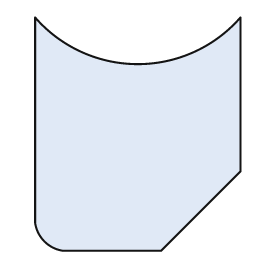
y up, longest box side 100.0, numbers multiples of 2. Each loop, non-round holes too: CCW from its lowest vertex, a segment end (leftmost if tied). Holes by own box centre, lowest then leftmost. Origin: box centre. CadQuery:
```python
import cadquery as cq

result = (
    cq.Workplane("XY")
    .moveTo(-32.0, -50.0)
    .lineTo(10.0, -50.0)
    .lineTo(44.0, -16.0)
    .lineTo(44.0, 50.0)
    .threePointArc((0.0, 30.0), (-44.0, 50.0))
    .lineTo(-44.0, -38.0)
    .threePointArc((-40.0, -46.0), (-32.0, -50.0))
    .close()
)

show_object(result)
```